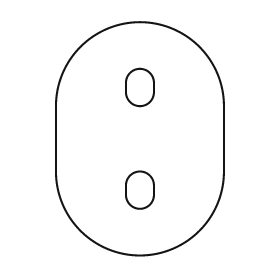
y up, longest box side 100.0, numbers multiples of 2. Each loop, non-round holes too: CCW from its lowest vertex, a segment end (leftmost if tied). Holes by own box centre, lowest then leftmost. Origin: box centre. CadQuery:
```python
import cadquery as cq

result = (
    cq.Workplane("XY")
    .moveTo(-36.0, -14.0)
    .threePointArc((0.0, -50.0), (36.0, -14.0))
    .lineTo(36.0, 14.0)
    .threePointArc((0.0, 50.0), (-36.0, 14.0))
    .close()
    .moveTo(-6.0, -24.0)
    .threePointArc((0.0, -30.0), (6.0, -24.0))
    .lineTo(6.0, -20.0)
    .threePointArc((0.0, -14.0), (-6.0, -20.0))
    .close()
    .moveTo(-6.0, 20.0)
    .threePointArc((0.0, 14.0), (6.0, 20.0))
    .lineTo(6.0, 24.0)
    .threePointArc((0.0, 30.0), (-6.0, 24.0))
    .close()
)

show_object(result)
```